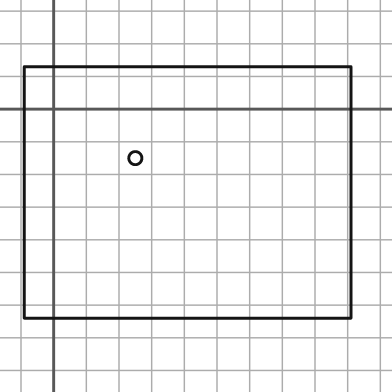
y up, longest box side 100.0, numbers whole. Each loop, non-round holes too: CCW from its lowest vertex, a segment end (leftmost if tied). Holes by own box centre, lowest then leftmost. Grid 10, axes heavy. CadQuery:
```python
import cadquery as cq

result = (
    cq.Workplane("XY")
    .moveTo(-9.0, -64.0)
    .lineTo(91.0, -64.0)
    .lineTo(91.0, 13.0)
    .lineTo(-9.0, 13.0)
    .close()
    .moveTo(25.0, -15.0)
    .circle(2.0)
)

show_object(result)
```